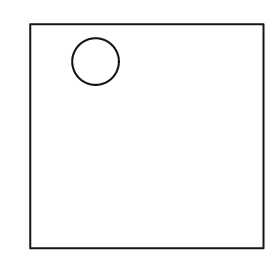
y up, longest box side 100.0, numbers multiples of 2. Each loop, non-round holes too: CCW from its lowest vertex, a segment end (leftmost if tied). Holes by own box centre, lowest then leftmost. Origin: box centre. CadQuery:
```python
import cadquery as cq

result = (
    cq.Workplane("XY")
    .moveTo(-50.0, -48.0)
    .lineTo(50.0, -48.0)
    .lineTo(50.0, 48.0)
    .lineTo(-50.0, 48.0)
    .close()
    .moveTo(-22.0, 32.0)
    .circle(10.0)
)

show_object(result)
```